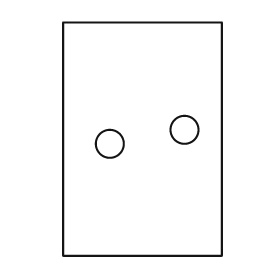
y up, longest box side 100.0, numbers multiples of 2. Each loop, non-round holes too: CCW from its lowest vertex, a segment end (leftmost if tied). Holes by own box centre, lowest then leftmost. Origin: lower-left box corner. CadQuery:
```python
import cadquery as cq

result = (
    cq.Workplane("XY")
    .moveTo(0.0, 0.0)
    .lineTo(68.0, 0.0)
    .lineTo(68.0, 100.0)
    .lineTo(0.0, 100.0)
    .close()
    .moveTo(20.0, 48.0)
    .circle(6.0)
    .moveTo(52.0, 54.0)
    .circle(6.0)
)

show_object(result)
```